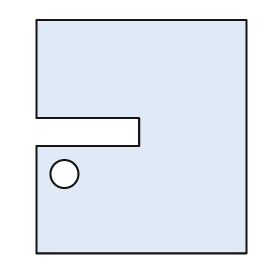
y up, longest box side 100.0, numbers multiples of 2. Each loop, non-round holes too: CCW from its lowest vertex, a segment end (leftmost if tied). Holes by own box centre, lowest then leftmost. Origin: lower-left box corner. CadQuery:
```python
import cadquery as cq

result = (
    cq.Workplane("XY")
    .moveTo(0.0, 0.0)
    .lineTo(90.0, 0.0)
    .lineTo(90.0, 100.0)
    .lineTo(0.0, 100.0)
    .lineTo(0.0, 58.0)
    .lineTo(44.0, 58.0)
    .lineTo(44.0, 46.0)
    .lineTo(0.0, 46.0)
    .close()
    .moveTo(12.0, 34.0)
    .circle(6.0)
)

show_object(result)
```